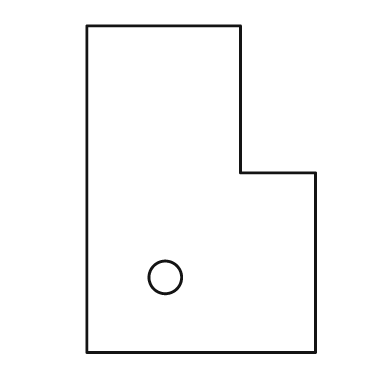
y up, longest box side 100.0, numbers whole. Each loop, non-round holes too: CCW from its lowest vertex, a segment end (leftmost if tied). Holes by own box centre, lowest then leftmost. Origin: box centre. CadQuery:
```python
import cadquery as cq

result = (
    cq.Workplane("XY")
    .moveTo(-35.0, -50.0)
    .lineTo(35.0, -50.0)
    .lineTo(35.0, 5.0)
    .lineTo(12.0, 5.0)
    .lineTo(12.0, 50.0)
    .lineTo(-35.0, 50.0)
    .close()
    .moveTo(-11.0, -27.0)
    .circle(5.0)
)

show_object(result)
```